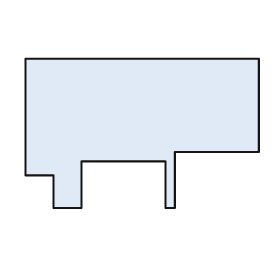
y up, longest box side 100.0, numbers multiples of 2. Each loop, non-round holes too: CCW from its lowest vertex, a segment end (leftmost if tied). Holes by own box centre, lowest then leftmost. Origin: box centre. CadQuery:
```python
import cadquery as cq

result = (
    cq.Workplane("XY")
    .moveTo(-38.0, -32.0)
    .lineTo(-26.0, -32.0)
    .lineTo(-26.0, -12.0)
    .lineTo(10.0, -12.0)
    .lineTo(10.0, -32.0)
    .lineTo(14.0, -32.0)
    .lineTo(14.0, -8.0)
    .lineTo(50.0, -8.0)
    .lineTo(50.0, 32.0)
    .lineTo(-50.0, 32.0)
    .lineTo(-50.0, -18.0)
    .lineTo(-38.0, -18.0)
    .close()
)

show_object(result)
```